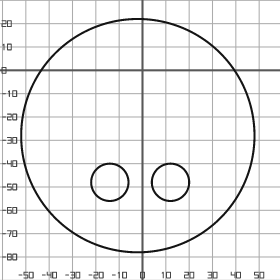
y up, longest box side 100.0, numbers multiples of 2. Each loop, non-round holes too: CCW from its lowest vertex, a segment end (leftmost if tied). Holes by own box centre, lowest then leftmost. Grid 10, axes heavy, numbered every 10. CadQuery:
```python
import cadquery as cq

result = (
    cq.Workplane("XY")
    .moveTo(-2.0, -28.0)
    .circle(50.0)
    .moveTo(-14.0, -48.0)
    .circle(8.0)
    .moveTo(12.0, -48.0)
    .circle(8.0)
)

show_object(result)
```